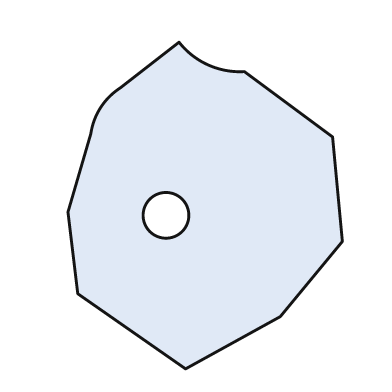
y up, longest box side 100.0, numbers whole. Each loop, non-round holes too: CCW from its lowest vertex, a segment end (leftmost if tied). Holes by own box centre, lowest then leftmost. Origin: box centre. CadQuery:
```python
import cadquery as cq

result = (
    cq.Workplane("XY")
    .moveTo(-6.0, -50.0)
    .lineTo(23.0, -34.0)
    .lineTo(42.0, -11.0)
    .lineTo(39.0, 21.0)
    .lineTo(12.0, 41.0)
    .threePointArc((1.0, 43.0), (-8.0, 50.0))
    .lineTo(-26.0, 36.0)
    .threePointArc((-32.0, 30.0), (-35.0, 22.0))
    .lineTo(-42.0, -2.0)
    .lineTo(-39.0, -27.0)
    .close()
    .moveTo(-12.0, -3.0)
    .circle(7.0)
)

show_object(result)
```